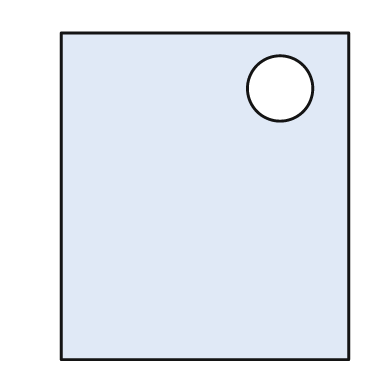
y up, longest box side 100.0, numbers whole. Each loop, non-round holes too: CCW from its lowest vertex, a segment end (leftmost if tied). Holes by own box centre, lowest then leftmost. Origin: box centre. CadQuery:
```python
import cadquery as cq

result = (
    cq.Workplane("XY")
    .moveTo(-44.0, -50.0)
    .lineTo(44.0, -50.0)
    .lineTo(44.0, 50.0)
    .lineTo(-44.0, 50.0)
    .close()
    .moveTo(23.0, 33.0)
    .circle(10.0)
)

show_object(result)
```